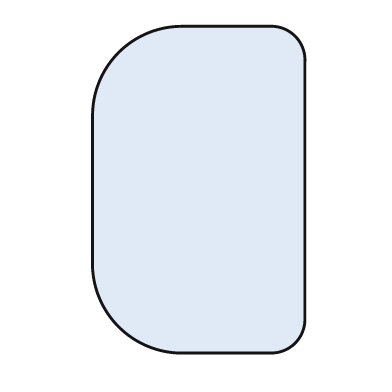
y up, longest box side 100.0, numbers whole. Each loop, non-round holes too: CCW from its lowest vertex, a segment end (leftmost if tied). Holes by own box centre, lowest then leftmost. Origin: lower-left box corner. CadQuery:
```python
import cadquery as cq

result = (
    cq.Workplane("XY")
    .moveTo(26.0, 0.0)
    .lineTo(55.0, 0.0)
    .threePointArc((62.0, 3.0), (65.0, 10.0))
    .lineTo(65.0, 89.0)
    .threePointArc((62.0, 97.0), (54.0, 100.0))
    .lineTo(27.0, 100.0)
    .threePointArc((8.0, 92.0), (0.0, 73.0))
    .lineTo(0.0, 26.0)
    .threePointArc((8.0, 8.0), (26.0, 0.0))
    .close()
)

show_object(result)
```